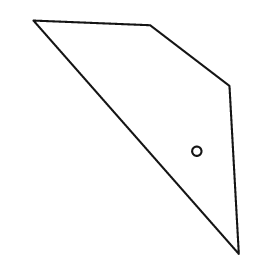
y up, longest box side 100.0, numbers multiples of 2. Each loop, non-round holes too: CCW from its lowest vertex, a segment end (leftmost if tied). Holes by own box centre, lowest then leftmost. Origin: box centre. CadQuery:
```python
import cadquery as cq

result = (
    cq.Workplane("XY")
    .moveTo(44.0, -50.0)
    .lineTo(40.0, 22.0)
    .lineTo(6.0, 48.0)
    .lineTo(-44.0, 50.0)
    .close()
    .moveTo(26.0, -6.0)
    .circle(2.0)
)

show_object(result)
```